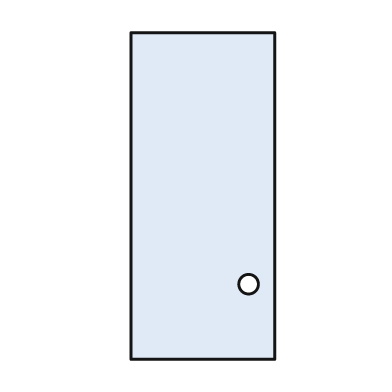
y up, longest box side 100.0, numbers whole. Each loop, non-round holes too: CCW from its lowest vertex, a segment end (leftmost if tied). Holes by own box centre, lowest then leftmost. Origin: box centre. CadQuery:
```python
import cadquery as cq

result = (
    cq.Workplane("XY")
    .moveTo(-22.0, -50.0)
    .lineTo(22.0, -50.0)
    .lineTo(22.0, 50.0)
    .lineTo(-22.0, 50.0)
    .close()
    .moveTo(14.0, -27.0)
    .circle(3.0)
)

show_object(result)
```